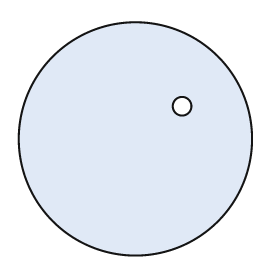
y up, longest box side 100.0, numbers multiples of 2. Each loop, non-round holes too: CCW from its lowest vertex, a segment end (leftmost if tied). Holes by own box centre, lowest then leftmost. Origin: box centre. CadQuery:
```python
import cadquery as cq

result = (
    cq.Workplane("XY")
    .moveTo(0.0, 0.0)
    .circle(50.0)
    .moveTo(20.0, 14.0)
    .circle(4.0)
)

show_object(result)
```